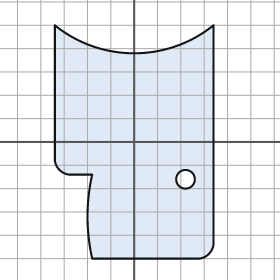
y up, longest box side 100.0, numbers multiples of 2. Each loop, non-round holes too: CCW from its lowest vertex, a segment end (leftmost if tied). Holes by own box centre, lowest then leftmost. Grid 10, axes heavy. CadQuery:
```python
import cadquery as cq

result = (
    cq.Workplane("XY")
    .moveTo(-18.0, -50.0)
    .lineTo(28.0, -50.0)
    .threePointArc((32.0, -48.0), (34.0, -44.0))
    .lineTo(34.0, 50.0)
    .threePointArc((0.0, 38.0), (-34.0, 50.0))
    .lineTo(-34.0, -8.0)
    .threePointArc((-32.0, -12.0), (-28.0, -14.0))
    .lineTo(-18.0, -14.0)
    .threePointArc((-20.0, -32.0), (-18.0, -50.0))
    .close()
    .moveTo(22.0, -16.0)
    .circle(4.0)
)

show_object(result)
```